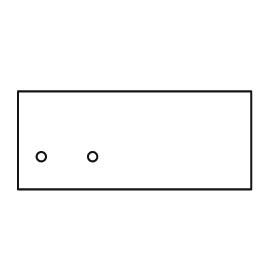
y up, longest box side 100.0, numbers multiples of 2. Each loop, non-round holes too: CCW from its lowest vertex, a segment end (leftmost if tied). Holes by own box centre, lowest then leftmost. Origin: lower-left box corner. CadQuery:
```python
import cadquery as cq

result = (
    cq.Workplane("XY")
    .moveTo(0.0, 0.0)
    .lineTo(100.0, 0.0)
    .lineTo(100.0, 42.0)
    .lineTo(0.0, 42.0)
    .close()
    .moveTo(10.0, 14.0)
    .circle(2.0)
    .moveTo(32.0, 14.0)
    .circle(2.0)
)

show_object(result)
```